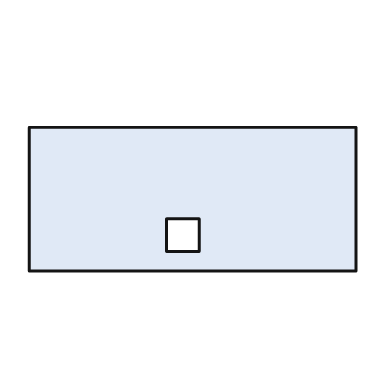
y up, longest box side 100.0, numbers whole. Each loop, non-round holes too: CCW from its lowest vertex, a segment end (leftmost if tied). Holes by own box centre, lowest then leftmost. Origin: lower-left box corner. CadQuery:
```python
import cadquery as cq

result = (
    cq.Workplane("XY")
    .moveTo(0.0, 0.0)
    .lineTo(100.0, 0.0)
    .lineTo(100.0, 44.0)
    .lineTo(0.0, 44.0)
    .close()
    .moveTo(42.0, 6.0)
    .lineTo(52.0, 6.0)
    .lineTo(52.0, 16.0)
    .lineTo(42.0, 16.0)
    .close()
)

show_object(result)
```